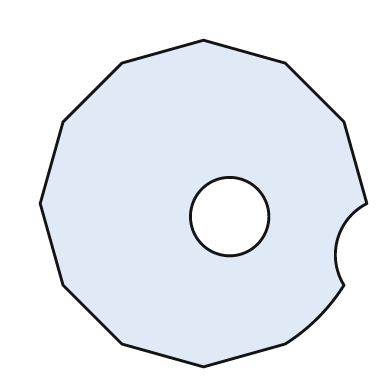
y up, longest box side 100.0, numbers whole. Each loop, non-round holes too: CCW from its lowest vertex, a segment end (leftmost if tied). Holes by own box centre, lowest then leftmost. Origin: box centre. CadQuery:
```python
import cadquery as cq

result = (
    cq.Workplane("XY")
    .moveTo(0.0, -50.0)
    .lineTo(25.0, -43.0)
    .threePointArc((35.0, -35.0), (43.0, -25.0))
    .threePointArc((41.0, -11.0), (50.0, 0.0))
    .lineTo(43.0, 25.0)
    .lineTo(25.0, 43.0)
    .lineTo(0.0, 50.0)
    .lineTo(-25.0, 43.0)
    .lineTo(-43.0, 25.0)
    .lineTo(-50.0, 0.0)
    .lineTo(-43.0, -25.0)
    .lineTo(-25.0, -43.0)
    .close()
    .moveTo(8.0, -4.0)
    .circle(12.0)
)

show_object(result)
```